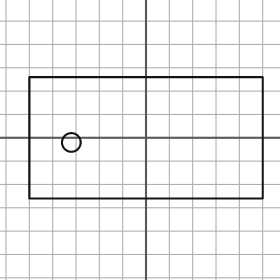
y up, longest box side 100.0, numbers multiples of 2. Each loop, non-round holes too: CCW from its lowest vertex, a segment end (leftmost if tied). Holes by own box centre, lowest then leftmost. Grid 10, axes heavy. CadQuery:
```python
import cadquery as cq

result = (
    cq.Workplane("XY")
    .moveTo(-50.0, -26.0)
    .lineTo(50.0, -26.0)
    .lineTo(50.0, 26.0)
    .lineTo(-50.0, 26.0)
    .close()
    .moveTo(-32.0, -2.0)
    .circle(4.0)
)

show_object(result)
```